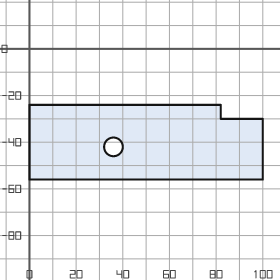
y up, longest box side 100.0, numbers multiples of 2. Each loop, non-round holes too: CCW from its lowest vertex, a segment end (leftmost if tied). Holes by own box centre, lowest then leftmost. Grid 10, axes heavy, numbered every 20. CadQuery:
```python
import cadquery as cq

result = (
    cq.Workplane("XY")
    .moveTo(0.0, -56.0)
    .lineTo(100.0, -56.0)
    .lineTo(100.0, -30.0)
    .lineTo(82.0, -30.0)
    .lineTo(82.0, -24.0)
    .lineTo(0.0, -24.0)
    .close()
    .moveTo(36.0, -42.0)
    .circle(4.0)
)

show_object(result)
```